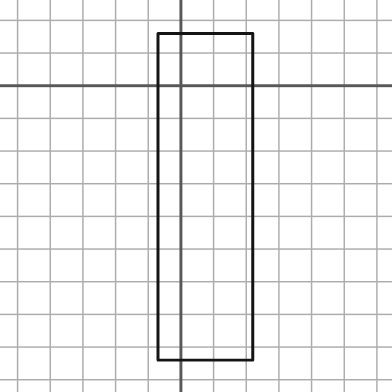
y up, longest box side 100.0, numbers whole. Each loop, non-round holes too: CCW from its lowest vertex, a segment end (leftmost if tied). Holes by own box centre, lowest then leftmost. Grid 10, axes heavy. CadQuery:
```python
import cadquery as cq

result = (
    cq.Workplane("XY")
    .moveTo(-7.0, -84.0)
    .lineTo(22.0, -84.0)
    .lineTo(22.0, 16.0)
    .lineTo(-7.0, 16.0)
    .close()
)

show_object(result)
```